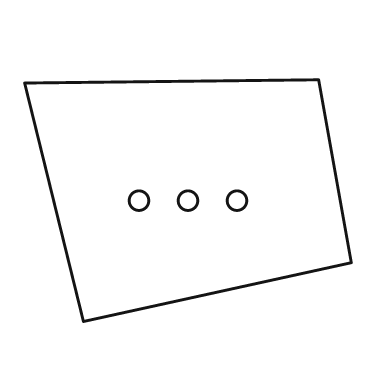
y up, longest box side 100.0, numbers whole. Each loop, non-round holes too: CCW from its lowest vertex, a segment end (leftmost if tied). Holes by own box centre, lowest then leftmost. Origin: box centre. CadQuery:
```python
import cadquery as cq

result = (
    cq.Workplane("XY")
    .moveTo(-32.0, -37.0)
    .lineTo(50.0, -19.0)
    .lineTo(40.0, 37.0)
    .lineTo(-50.0, 36.0)
    .close()
    .moveTo(-15.0, 0.0)
    .circle(3.0)
    .moveTo(0.0, 0.0)
    .circle(3.0)
    .moveTo(15.0, 0.0)
    .circle(3.0)
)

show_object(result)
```